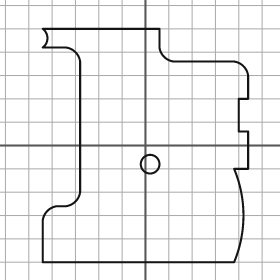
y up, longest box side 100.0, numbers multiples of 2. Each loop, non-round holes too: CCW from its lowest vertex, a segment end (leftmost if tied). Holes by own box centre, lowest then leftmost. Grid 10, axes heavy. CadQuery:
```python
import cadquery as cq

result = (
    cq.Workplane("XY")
    .moveTo(-44.0, -50.0)
    .lineTo(38.0, -50.0)
    .threePointArc((42.0, -30.0), (38.0, -10.0))
    .lineTo(44.0, -10.0)
    .lineTo(44.0, 6.0)
    .lineTo(40.0, 6.0)
    .lineTo(40.0, 20.0)
    .lineTo(44.0, 20.0)
    .lineTo(44.0, 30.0)
    .threePointArc((42.0, 34.0), (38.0, 36.0))
    .lineTo(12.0, 36.0)
    .threePointArc((8.0, 38.0), (6.0, 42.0))
    .lineTo(6.0, 50.0)
    .lineTo(-44.0, 50.0)
    .threePointArc((-42.0, 46.0), (-44.0, 42.0))
    .lineTo(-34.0, 42.0)
    .threePointArc((-30.0, 40.0), (-28.0, 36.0))
    .lineTo(-28.0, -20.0)
    .threePointArc((-30.0, -24.0), (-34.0, -26.0))
    .lineTo(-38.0, -26.0)
    .threePointArc((-42.0, -28.0), (-44.0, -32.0))
    .close()
    .moveTo(2.0, -8.0)
    .circle(4.0)
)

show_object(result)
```